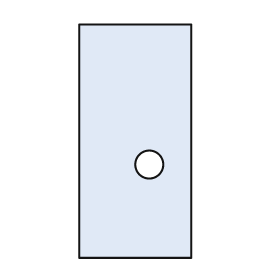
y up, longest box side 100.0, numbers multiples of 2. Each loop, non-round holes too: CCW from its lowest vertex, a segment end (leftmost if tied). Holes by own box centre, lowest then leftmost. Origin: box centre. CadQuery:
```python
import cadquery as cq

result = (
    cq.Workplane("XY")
    .moveTo(-24.0, -50.0)
    .lineTo(24.0, -50.0)
    .lineTo(24.0, 50.0)
    .lineTo(-24.0, 50.0)
    .close()
    .moveTo(6.0, -10.0)
    .circle(6.0)
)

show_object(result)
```